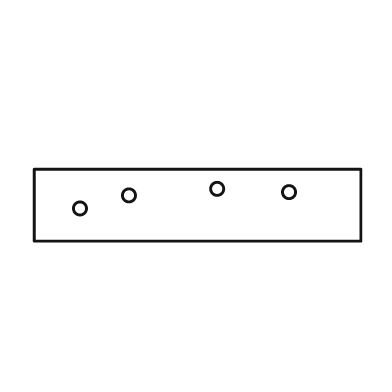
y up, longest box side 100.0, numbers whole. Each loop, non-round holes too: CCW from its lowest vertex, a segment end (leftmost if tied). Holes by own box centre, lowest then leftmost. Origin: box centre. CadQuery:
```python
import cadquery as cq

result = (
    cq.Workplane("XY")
    .moveTo(-50.0, -11.0)
    .lineTo(50.0, -11.0)
    .lineTo(50.0, 11.0)
    .lineTo(-50.0, 11.0)
    .close()
    .moveTo(-36.0, -1.0)
    .circle(2.0)
    .moveTo(-21.0, 3.0)
    .circle(2.0)
    .moveTo(28.0, 4.0)
    .circle(2.0)
    .moveTo(6.0, 5.0)
    .circle(2.0)
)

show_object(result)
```